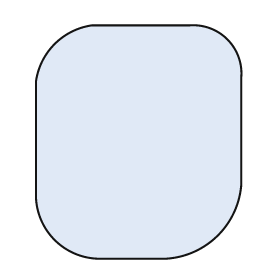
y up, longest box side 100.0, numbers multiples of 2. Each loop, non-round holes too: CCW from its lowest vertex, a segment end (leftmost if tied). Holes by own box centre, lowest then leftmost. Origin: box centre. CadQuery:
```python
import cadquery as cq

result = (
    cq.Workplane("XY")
    .moveTo(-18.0, -50.0)
    .lineTo(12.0, -50.0)
    .threePointArc((34.0, -40.0), (44.0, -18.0))
    .lineTo(44.0, 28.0)
    .threePointArc((38.0, 44.0), (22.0, 50.0))
    .lineTo(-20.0, 50.0)
    .threePointArc((-36.0, 42.0), (-44.0, 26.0))
    .lineTo(-44.0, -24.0)
    .threePointArc((-36.0, -42.0), (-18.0, -50.0))
    .close()
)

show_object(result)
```